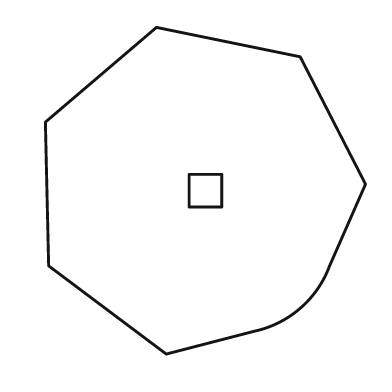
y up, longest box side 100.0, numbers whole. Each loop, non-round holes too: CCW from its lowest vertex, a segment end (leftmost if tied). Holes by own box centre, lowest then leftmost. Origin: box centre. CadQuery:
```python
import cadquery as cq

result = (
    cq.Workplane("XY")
    .moveTo(-12.0, -50.0)
    .lineTo(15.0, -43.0)
    .threePointArc((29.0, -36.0), (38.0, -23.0))
    .lineTo(49.0, 2.0)
    .lineTo(29.0, 41.0)
    .lineTo(-15.0, 50.0)
    .lineTo(-49.0, 21.0)
    .lineTo(-48.0, -23.0)
    .close()
    .moveTo(-5.0, -5.0)
    .lineTo(5.0, -5.0)
    .lineTo(5.0, 5.0)
    .lineTo(-5.0, 5.0)
    .close()
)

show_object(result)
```